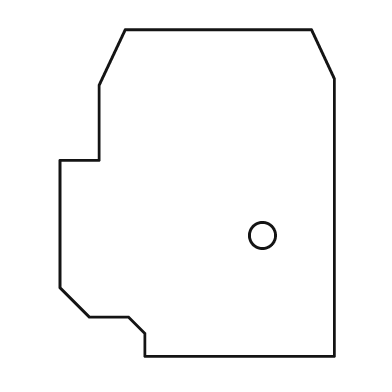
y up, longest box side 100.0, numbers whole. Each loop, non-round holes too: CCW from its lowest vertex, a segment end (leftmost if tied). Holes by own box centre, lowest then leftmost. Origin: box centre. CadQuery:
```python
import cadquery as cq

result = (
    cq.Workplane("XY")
    .moveTo(-16.0, -50.0)
    .lineTo(42.0, -50.0)
    .lineTo(42.0, 35.0)
    .lineTo(35.0, 50.0)
    .lineTo(-22.0, 50.0)
    .lineTo(-30.0, 33.0)
    .lineTo(-30.0, 10.0)
    .lineTo(-42.0, 10.0)
    .lineTo(-42.0, -29.0)
    .lineTo(-33.0, -38.0)
    .lineTo(-21.0, -38.0)
    .lineTo(-16.0, -43.0)
    .close()
    .moveTo(20.0, -13.0)
    .circle(4.0)
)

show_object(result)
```